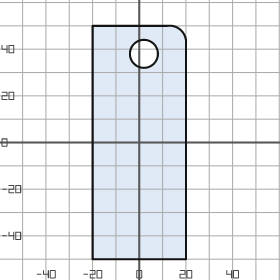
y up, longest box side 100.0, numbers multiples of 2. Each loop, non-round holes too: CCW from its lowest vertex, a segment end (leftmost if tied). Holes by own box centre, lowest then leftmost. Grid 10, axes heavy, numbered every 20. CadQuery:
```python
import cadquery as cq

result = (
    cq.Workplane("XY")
    .moveTo(-20.0, -50.0)
    .lineTo(20.0, -50.0)
    .lineTo(20.0, 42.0)
    .threePointArc((18.0, 48.0), (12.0, 50.0))
    .lineTo(-20.0, 50.0)
    .close()
    .moveTo(2.0, 38.0)
    .circle(6.0)
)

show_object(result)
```